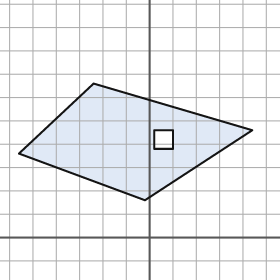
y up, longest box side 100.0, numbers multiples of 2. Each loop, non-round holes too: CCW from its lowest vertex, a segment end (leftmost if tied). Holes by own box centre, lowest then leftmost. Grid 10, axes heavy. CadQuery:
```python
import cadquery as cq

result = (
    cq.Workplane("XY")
    .moveTo(-2.0, 16.0)
    .lineTo(44.0, 46.0)
    .lineTo(-24.0, 66.0)
    .lineTo(-56.0, 36.0)
    .close()
    .moveTo(2.0, 38.0)
    .lineTo(10.0, 38.0)
    .lineTo(10.0, 46.0)
    .lineTo(2.0, 46.0)
    .close()
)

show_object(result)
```